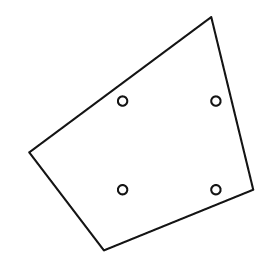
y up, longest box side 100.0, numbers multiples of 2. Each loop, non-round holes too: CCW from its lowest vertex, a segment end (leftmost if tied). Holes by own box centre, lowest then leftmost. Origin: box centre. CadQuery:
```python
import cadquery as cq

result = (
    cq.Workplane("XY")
    .moveTo(-16.0, -50.0)
    .lineTo(48.0, -24.0)
    .lineTo(30.0, 50.0)
    .lineTo(-48.0, -8.0)
    .close()
    .moveTo(-8.0, -24.0)
    .circle(2.0)
    .moveTo(32.0, -24.0)
    .circle(2.0)
    .moveTo(-8.0, 14.0)
    .circle(2.0)
    .moveTo(32.0, 14.0)
    .circle(2.0)
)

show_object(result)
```